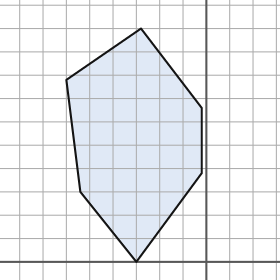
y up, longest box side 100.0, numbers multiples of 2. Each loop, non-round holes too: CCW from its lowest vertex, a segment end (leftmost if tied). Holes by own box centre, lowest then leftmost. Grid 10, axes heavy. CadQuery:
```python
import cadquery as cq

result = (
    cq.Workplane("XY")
    .moveTo(-30.0, 0.0)
    .lineTo(-2.0, 38.0)
    .lineTo(-2.0, 66.0)
    .lineTo(-28.0, 100.0)
    .lineTo(-60.0, 78.0)
    .lineTo(-54.0, 30.0)
    .close()
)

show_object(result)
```